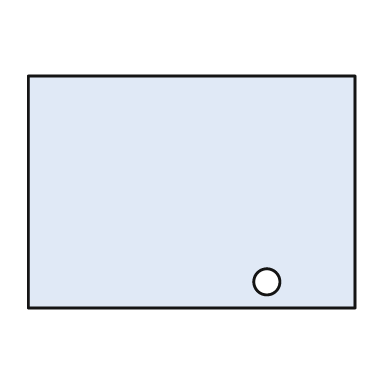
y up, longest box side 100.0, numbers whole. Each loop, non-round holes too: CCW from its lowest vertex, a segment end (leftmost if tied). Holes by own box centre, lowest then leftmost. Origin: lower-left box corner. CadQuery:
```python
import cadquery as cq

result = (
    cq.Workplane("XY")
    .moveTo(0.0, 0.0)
    .lineTo(100.0, 0.0)
    .lineTo(100.0, 71.0)
    .lineTo(0.0, 71.0)
    .close()
    .moveTo(73.0, 8.0)
    .circle(4.0)
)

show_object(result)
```